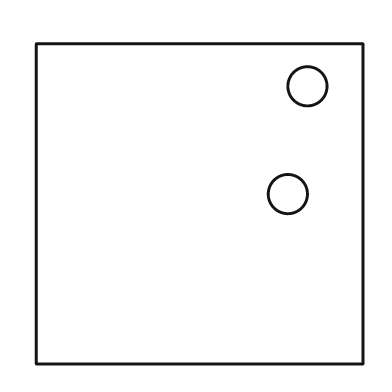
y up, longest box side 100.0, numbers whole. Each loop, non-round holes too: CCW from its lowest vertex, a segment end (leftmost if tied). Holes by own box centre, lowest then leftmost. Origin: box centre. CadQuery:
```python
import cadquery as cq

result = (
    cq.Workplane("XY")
    .moveTo(-50.0, -49.0)
    .lineTo(50.0, -49.0)
    .lineTo(50.0, 49.0)
    .lineTo(-50.0, 49.0)
    .close()
    .moveTo(27.0, 3.0)
    .circle(6.0)
    .moveTo(33.0, 36.0)
    .circle(6.0)
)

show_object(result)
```